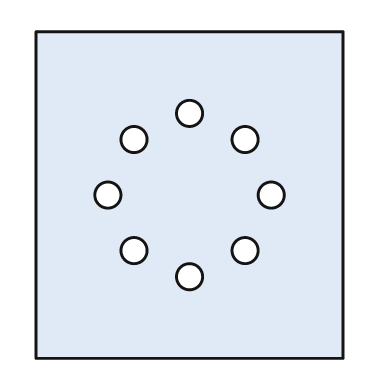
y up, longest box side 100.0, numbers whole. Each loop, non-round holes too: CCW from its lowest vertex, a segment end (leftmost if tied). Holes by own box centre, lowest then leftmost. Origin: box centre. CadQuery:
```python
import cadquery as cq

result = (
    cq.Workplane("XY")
    .moveTo(-47.0, -50.0)
    .lineTo(47.0, -50.0)
    .lineTo(47.0, 50.0)
    .lineTo(-47.0, 50.0)
    .close()
    .moveTo(0.0, -25.0)
    .circle(4.0)
    .moveTo(-17.0, -17.0)
    .circle(4.0)
    .moveTo(17.0, -17.0)
    .circle(4.0)
    .moveTo(-25.0, 0.0)
    .circle(4.0)
    .moveTo(25.0, 0.0)
    .circle(4.0)
    .moveTo(-17.0, 17.0)
    .circle(4.0)
    .moveTo(17.0, 17.0)
    .circle(4.0)
    .moveTo(0.0, 25.0)
    .circle(4.0)
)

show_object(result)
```